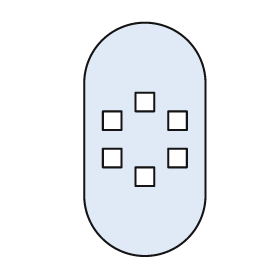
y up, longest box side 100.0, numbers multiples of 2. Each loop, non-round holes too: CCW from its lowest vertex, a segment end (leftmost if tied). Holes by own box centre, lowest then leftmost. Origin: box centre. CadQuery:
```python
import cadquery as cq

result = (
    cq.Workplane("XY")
    .moveTo(-26.0, -24.0)
    .threePointArc((0.0, -50.0), (26.0, -24.0))
    .lineTo(26.0, 24.0)
    .threePointArc((0.0, 50.0), (-26.0, 24.0))
    .close()
    .moveTo(-4.0, -20.0)
    .lineTo(4.0, -20.0)
    .lineTo(4.0, -12.0)
    .lineTo(-4.0, -12.0)
    .close()
    .moveTo(-18.0, -12.0)
    .lineTo(-10.0, -12.0)
    .lineTo(-10.0, -4.0)
    .lineTo(-18.0, -4.0)
    .close()
    .moveTo(10.0, -12.0)
    .lineTo(18.0, -12.0)
    .lineTo(18.0, -4.0)
    .lineTo(10.0, -4.0)
    .close()
    .moveTo(-18.0, 4.0)
    .lineTo(-10.0, 4.0)
    .lineTo(-10.0, 12.0)
    .lineTo(-18.0, 12.0)
    .close()
    .moveTo(10.0, 4.0)
    .lineTo(18.0, 4.0)
    .lineTo(18.0, 12.0)
    .lineTo(10.0, 12.0)
    .close()
    .moveTo(-4.0, 12.0)
    .lineTo(4.0, 12.0)
    .lineTo(4.0, 20.0)
    .lineTo(-4.0, 20.0)
    .close()
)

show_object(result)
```